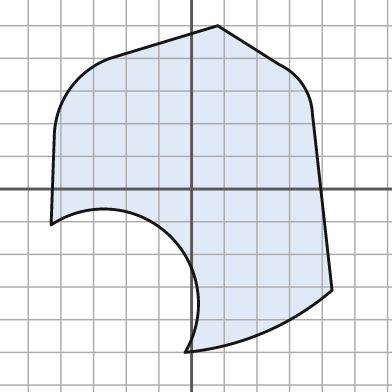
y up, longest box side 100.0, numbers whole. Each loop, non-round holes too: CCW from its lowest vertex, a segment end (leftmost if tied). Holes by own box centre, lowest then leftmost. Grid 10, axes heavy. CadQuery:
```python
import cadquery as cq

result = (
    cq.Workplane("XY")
    .moveTo(-2.0, -50.0)
    .threePointArc((22.0, -44.0), (43.0, -31.0))
    .lineTo(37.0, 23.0)
    .threePointArc((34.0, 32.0), (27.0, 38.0))
    .lineTo(8.0, 50.0)
    .lineTo(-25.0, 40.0)
    .threePointArc((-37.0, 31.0), (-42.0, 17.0))
    .lineTo(-43.0, -11.0)
    .threePointArc((-7.0, -14.0), (-2.0, -50.0))
    .close()
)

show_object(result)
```